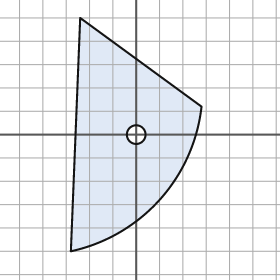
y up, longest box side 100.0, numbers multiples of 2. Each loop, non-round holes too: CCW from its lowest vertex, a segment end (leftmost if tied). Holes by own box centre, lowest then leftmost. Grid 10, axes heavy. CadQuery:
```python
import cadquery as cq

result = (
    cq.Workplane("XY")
    .moveTo(-28.0, -50.0)
    .threePointArc((10.0, -28.0), (28.0, 12.0))
    .lineTo(-24.0, 50.0)
    .close()
    .moveTo(0.0, 0.0)
    .circle(4.0)
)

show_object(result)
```